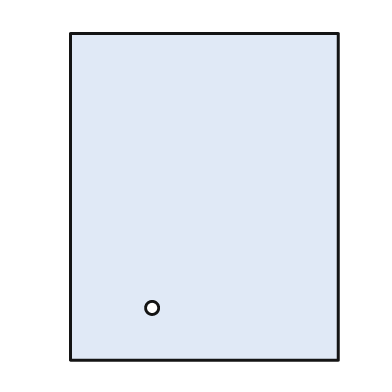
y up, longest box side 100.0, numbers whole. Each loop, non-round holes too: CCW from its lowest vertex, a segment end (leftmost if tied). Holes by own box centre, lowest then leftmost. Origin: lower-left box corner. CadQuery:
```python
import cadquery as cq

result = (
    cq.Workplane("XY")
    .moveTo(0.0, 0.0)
    .lineTo(82.0, 0.0)
    .lineTo(82.0, 100.0)
    .lineTo(0.0, 100.0)
    .close()
    .moveTo(25.0, 16.0)
    .circle(2.0)
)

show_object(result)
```